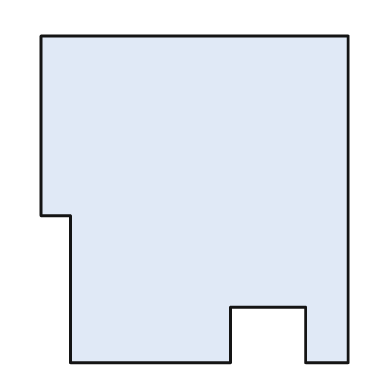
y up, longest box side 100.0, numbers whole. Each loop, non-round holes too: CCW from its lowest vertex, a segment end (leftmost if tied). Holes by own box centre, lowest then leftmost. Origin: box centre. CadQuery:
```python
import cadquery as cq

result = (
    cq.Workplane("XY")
    .moveTo(-38.0, -50.0)
    .lineTo(11.0, -50.0)
    .lineTo(11.0, -33.0)
    .lineTo(34.0, -33.0)
    .lineTo(34.0, -50.0)
    .lineTo(47.0, -50.0)
    .lineTo(47.0, 50.0)
    .lineTo(-47.0, 50.0)
    .lineTo(-47.0, -5.0)
    .lineTo(-38.0, -5.0)
    .close()
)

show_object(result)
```